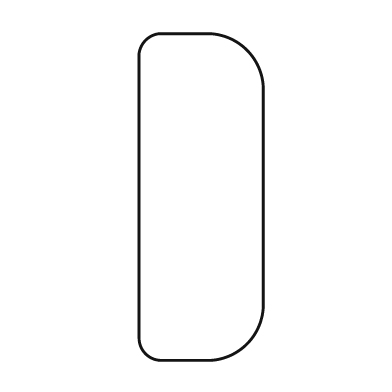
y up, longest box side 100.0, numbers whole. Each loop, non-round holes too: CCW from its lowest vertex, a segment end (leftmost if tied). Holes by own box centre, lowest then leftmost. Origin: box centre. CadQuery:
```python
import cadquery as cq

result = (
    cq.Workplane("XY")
    .moveTo(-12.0, -50.0)
    .lineTo(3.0, -50.0)
    .threePointArc((14.0, -45.0), (19.0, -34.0))
    .lineTo(19.0, 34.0)
    .threePointArc((14.0, 45.0), (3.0, 50.0))
    .lineTo(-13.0, 50.0)
    .threePointArc((-17.0, 48.0), (-19.0, 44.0))
    .lineTo(-19.0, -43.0)
    .threePointArc((-17.0, -48.0), (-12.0, -50.0))
    .close()
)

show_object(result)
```